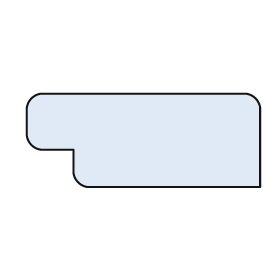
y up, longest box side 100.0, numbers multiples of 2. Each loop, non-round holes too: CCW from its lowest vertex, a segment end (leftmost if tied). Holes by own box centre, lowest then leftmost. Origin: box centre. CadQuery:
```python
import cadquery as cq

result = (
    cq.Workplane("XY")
    .moveTo(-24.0, -20.0)
    .lineTo(50.0, -20.0)
    .lineTo(50.0, 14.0)
    .threePointArc((48.0, 18.0), (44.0, 20.0))
    .lineTo(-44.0, 20.0)
    .threePointArc((-48.0, 18.0), (-50.0, 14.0))
    .lineTo(-50.0, 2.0)
    .threePointArc((-48.0, -2.0), (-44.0, -4.0))
    .lineTo(-30.0, -4.0)
    .lineTo(-30.0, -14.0)
    .threePointArc((-28.0, -18.0), (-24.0, -20.0))
    .close()
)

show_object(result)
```